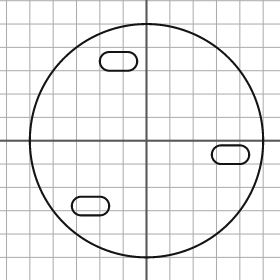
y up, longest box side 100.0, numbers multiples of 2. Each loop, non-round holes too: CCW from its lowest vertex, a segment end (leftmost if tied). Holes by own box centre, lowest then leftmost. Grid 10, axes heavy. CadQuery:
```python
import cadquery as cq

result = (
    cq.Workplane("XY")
    .moveTo(0.0, 0.0)
    .circle(50.0)
    .moveTo(-28.0, -32.0)
    .lineTo(-20.0, -32.0)
    .threePointArc((-16.0, -28.0), (-20.0, -24.0))
    .lineTo(-28.0, -24.0)
    .threePointArc((-32.0, -28.0), (-28.0, -32.0))
    .close()
    .moveTo(32.0, -10.0)
    .lineTo(40.0, -10.0)
    .threePointArc((44.0, -6.0), (40.0, -2.0))
    .lineTo(32.0, -2.0)
    .threePointArc((28.0, -6.0), (32.0, -10.0))
    .close()
    .moveTo(-16.0, 30.0)
    .lineTo(-8.0, 30.0)
    .threePointArc((-4.0, 34.0), (-8.0, 38.0))
    .lineTo(-16.0, 38.0)
    .threePointArc((-20.0, 34.0), (-16.0, 30.0))
    .close()
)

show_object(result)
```